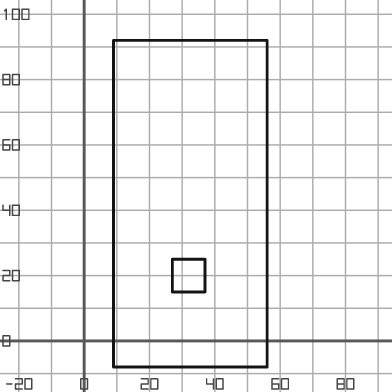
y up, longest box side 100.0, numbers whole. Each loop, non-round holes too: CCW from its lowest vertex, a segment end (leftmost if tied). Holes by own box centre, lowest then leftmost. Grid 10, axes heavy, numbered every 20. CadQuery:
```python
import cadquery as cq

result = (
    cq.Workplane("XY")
    .moveTo(9.0, -8.0)
    .lineTo(56.0, -8.0)
    .lineTo(56.0, 92.0)
    .lineTo(9.0, 92.0)
    .close()
    .moveTo(27.0, 15.0)
    .lineTo(37.0, 15.0)
    .lineTo(37.0, 25.0)
    .lineTo(27.0, 25.0)
    .close()
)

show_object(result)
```